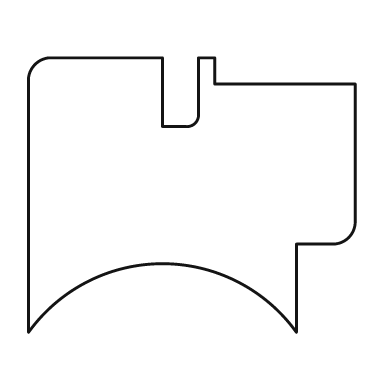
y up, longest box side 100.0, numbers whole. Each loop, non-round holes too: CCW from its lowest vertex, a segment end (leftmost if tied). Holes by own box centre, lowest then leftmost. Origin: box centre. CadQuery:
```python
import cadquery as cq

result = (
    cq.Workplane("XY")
    .moveTo(-50.0, -42.0)
    .threePointArc((-9.0, -21.0), (32.0, -42.0))
    .lineTo(32.0, -15.0)
    .lineTo(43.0, -15.0)
    .threePointArc((48.0, -13.0), (50.0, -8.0))
    .lineTo(50.0, 34.0)
    .lineTo(7.0, 34.0)
    .lineTo(7.0, 42.0)
    .lineTo(2.0, 42.0)
    .lineTo(2.0, 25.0)
    .threePointArc((1.0, 22.0), (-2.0, 21.0))
    .lineTo(-9.0, 21.0)
    .lineTo(-9.0, 42.0)
    .lineTo(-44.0, 42.0)
    .threePointArc((-48.0, 40.0), (-50.0, 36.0))
    .close()
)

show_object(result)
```